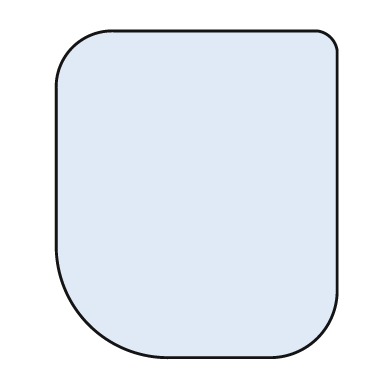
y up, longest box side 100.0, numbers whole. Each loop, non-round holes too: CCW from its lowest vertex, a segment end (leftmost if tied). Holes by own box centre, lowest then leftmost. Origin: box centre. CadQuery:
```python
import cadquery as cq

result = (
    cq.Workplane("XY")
    .moveTo(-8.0, -50.0)
    .lineTo(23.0, -50.0)
    .threePointArc((37.0, -44.0), (43.0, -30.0))
    .lineTo(43.0, 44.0)
    .threePointArc((41.0, 48.0), (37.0, 50.0))
    .lineTo(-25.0, 50.0)
    .threePointArc((-38.0, 45.0), (-43.0, 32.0))
    .lineTo(-43.0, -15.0)
    .threePointArc((-33.0, -40.0), (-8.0, -50.0))
    .close()
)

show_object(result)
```